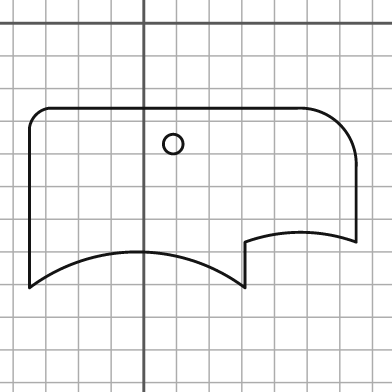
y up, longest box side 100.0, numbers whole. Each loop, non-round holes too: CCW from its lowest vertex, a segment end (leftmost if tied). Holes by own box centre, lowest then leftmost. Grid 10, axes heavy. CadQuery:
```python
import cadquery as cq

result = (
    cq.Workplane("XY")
    .moveTo(-35.0, -81.0)
    .threePointArc((-2.0, -70.0), (31.0, -81.0))
    .lineTo(31.0, -67.0)
    .threePointArc((48.0, -64.0), (65.0, -67.0))
    .lineTo(65.0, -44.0)
    .threePointArc((60.0, -31.0), (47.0, -26.0))
    .lineTo(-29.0, -26.0)
    .threePointArc((-33.0, -28.0), (-35.0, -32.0))
    .close()
    .moveTo(9.0, -37.0)
    .circle(3.0)
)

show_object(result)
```